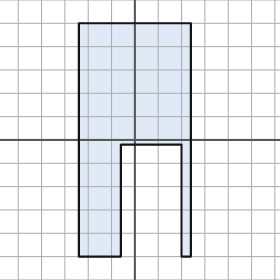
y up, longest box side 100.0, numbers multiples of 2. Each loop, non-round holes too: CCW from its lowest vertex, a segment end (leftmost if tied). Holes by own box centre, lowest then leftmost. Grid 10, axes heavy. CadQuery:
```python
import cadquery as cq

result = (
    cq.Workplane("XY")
    .moveTo(-24.0, -50.0)
    .lineTo(-6.0, -50.0)
    .lineTo(-6.0, -2.0)
    .lineTo(20.0, -2.0)
    .lineTo(20.0, -50.0)
    .lineTo(24.0, -50.0)
    .lineTo(24.0, 50.0)
    .lineTo(-24.0, 50.0)
    .close()
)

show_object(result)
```